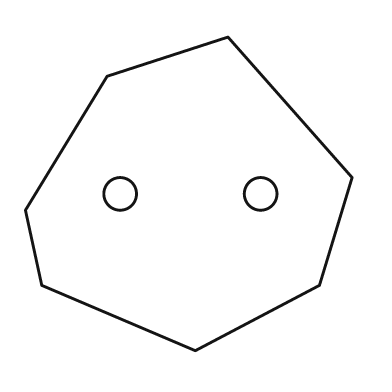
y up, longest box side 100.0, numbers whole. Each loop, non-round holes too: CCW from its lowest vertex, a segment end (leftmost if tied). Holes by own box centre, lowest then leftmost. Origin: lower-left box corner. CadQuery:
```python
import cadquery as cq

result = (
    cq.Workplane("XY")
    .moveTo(52.0, 0.0)
    .lineTo(90.0, 20.0)
    .lineTo(100.0, 53.0)
    .lineTo(62.0, 96.0)
    .lineTo(25.0, 84.0)
    .lineTo(0.0, 43.0)
    .lineTo(5.0, 20.0)
    .close()
    .moveTo(29.0, 48.0)
    .circle(5.0)
    .moveTo(72.0, 48.0)
    .circle(5.0)
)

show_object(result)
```